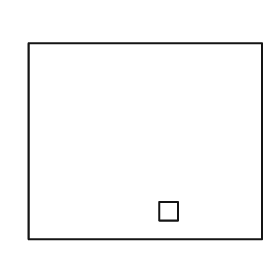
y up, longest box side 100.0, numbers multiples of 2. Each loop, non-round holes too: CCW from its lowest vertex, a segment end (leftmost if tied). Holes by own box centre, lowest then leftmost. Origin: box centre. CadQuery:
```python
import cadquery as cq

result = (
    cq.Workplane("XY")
    .moveTo(-50.0, -42.0)
    .lineTo(50.0, -42.0)
    .lineTo(50.0, 42.0)
    .lineTo(-50.0, 42.0)
    .close()
    .moveTo(6.0, -34.0)
    .lineTo(14.0, -34.0)
    .lineTo(14.0, -26.0)
    .lineTo(6.0, -26.0)
    .close()
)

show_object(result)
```